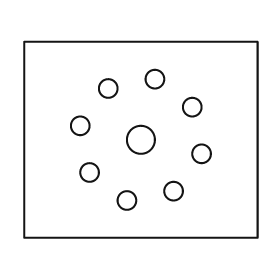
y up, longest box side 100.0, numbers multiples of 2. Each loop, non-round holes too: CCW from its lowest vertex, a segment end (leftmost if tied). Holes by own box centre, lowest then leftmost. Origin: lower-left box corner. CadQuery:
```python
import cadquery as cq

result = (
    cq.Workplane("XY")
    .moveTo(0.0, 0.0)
    .lineTo(100.0, 0.0)
    .lineTo(100.0, 84.0)
    .lineTo(0.0, 84.0)
    .close()
    .moveTo(44.0, 16.0)
    .circle(4.0)
    .moveTo(64.0, 20.0)
    .circle(4.0)
    .moveTo(28.0, 28.0)
    .circle(4.0)
    .moveTo(76.0, 36.0)
    .circle(4.0)
    .moveTo(50.0, 42.0)
    .circle(6.0)
    .moveTo(24.0, 48.0)
    .circle(4.0)
    .moveTo(72.0, 56.0)
    .circle(4.0)
    .moveTo(36.0, 64.0)
    .circle(4.0)
    .moveTo(56.0, 68.0)
    .circle(4.0)
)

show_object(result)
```